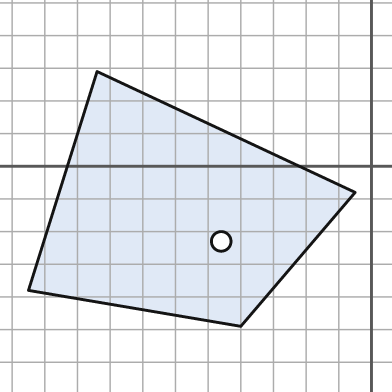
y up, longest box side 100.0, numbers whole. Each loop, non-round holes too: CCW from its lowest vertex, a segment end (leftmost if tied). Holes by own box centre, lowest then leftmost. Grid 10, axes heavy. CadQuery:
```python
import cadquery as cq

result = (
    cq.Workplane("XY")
    .moveTo(-40.0, -49.0)
    .lineTo(-5.0, -8.0)
    .lineTo(-84.0, 29.0)
    .lineTo(-105.0, -38.0)
    .close()
    .moveTo(-46.0, -23.0)
    .circle(3.0)
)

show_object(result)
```